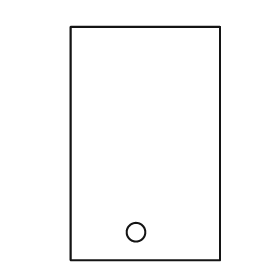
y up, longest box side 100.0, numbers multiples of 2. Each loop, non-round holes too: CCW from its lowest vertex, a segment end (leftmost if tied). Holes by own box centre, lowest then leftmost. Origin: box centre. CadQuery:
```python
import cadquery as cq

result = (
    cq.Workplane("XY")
    .moveTo(-32.0, -50.0)
    .lineTo(32.0, -50.0)
    .lineTo(32.0, 50.0)
    .lineTo(-32.0, 50.0)
    .close()
    .moveTo(-4.0, -38.0)
    .circle(4.0)
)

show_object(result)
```